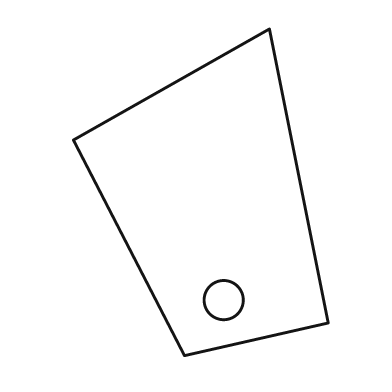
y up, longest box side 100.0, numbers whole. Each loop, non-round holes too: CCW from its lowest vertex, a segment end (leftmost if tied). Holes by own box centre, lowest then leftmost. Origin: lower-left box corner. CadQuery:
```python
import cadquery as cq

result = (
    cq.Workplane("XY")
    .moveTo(34.0, 0.0)
    .lineTo(78.0, 10.0)
    .lineTo(60.0, 100.0)
    .lineTo(0.0, 66.0)
    .close()
    .moveTo(46.0, 17.0)
    .circle(6.0)
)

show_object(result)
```